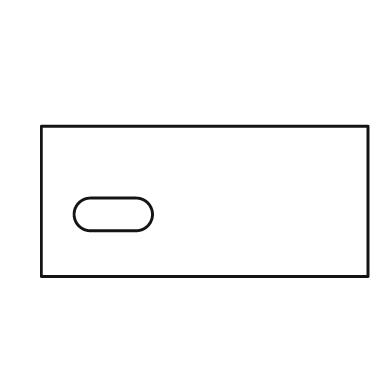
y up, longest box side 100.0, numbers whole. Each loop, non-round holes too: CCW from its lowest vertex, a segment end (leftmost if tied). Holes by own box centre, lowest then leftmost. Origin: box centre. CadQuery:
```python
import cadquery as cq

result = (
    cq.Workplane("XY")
    .moveTo(-50.0, -23.0)
    .lineTo(50.0, -23.0)
    .lineTo(50.0, 23.0)
    .lineTo(-50.0, 23.0)
    .close()
    .moveTo(-35.0, -9.0)
    .lineTo(-21.0, -9.0)
    .threePointArc((-16.0, -4.0), (-21.0, 1.0))
    .lineTo(-35.0, 1.0)
    .threePointArc((-40.0, -4.0), (-35.0, -9.0))
    .close()
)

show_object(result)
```